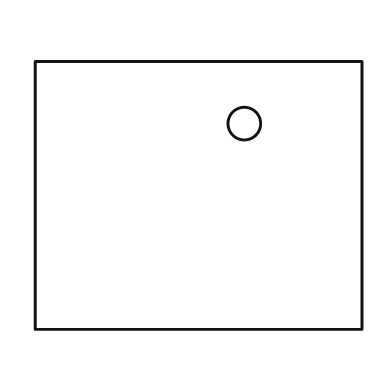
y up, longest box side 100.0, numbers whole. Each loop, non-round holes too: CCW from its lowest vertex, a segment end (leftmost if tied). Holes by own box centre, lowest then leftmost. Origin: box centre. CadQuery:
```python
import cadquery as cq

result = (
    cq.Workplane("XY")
    .moveTo(-50.0, -41.0)
    .lineTo(50.0, -41.0)
    .lineTo(50.0, 41.0)
    .lineTo(-50.0, 41.0)
    .close()
    .moveTo(14.0, 22.0)
    .circle(5.0)
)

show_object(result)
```